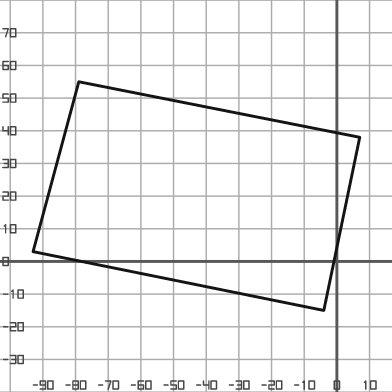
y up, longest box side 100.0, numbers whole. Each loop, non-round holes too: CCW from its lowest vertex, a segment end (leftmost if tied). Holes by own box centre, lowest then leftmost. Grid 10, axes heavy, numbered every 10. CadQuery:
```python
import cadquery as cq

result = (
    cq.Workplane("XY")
    .moveTo(-4.0, -15.0)
    .lineTo(7.0, 38.0)
    .lineTo(-79.0, 55.0)
    .lineTo(-93.0, 3.0)
    .close()
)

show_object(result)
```